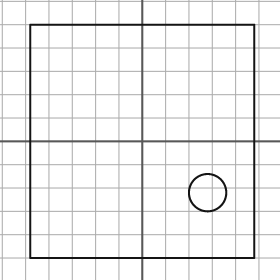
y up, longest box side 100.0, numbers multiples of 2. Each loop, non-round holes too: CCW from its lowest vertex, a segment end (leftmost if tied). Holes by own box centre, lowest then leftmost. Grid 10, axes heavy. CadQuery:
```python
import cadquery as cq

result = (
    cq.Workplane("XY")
    .moveTo(-48.0, -50.0)
    .lineTo(48.0, -50.0)
    .lineTo(48.0, 50.0)
    .lineTo(-48.0, 50.0)
    .close()
    .moveTo(28.0, -22.0)
    .circle(8.0)
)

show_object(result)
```